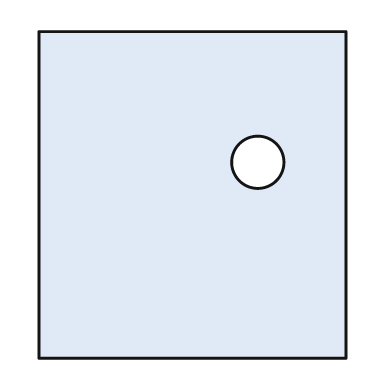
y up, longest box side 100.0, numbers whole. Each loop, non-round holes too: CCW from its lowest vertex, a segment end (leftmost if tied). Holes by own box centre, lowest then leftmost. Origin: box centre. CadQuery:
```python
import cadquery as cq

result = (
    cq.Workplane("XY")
    .moveTo(-47.0, -50.0)
    .lineTo(47.0, -50.0)
    .lineTo(47.0, 50.0)
    .lineTo(-47.0, 50.0)
    .close()
    .moveTo(20.0, 10.0)
    .circle(8.0)
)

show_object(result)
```